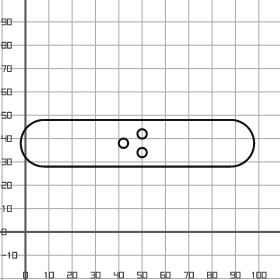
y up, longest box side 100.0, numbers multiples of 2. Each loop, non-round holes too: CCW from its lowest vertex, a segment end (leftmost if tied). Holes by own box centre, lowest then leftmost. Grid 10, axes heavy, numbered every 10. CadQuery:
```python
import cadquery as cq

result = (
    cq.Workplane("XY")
    .moveTo(8.0, 28.0)
    .lineTo(88.0, 28.0)
    .threePointArc((98.0, 38.0), (88.0, 48.0))
    .lineTo(8.0, 48.0)
    .threePointArc((-2.0, 38.0), (8.0, 28.0))
    .close()
    .moveTo(50.0, 34.0)
    .circle(2.0)
    .moveTo(42.0, 38.0)
    .circle(2.0)
    .moveTo(50.0, 42.0)
    .circle(2.0)
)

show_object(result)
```